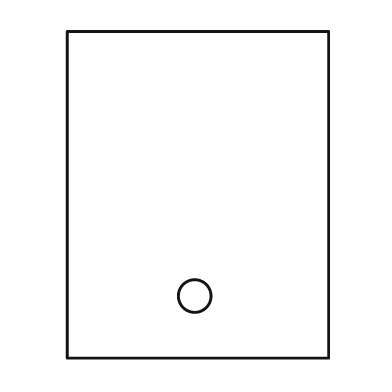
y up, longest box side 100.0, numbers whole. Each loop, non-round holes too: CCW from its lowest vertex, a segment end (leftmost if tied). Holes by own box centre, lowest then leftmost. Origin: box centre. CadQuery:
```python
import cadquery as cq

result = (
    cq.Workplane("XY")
    .moveTo(-40.0, -50.0)
    .lineTo(40.0, -50.0)
    .lineTo(40.0, 50.0)
    .lineTo(-40.0, 50.0)
    .close()
    .moveTo(-1.0, -31.0)
    .circle(5.0)
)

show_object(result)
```